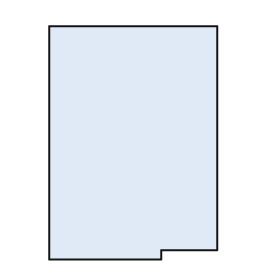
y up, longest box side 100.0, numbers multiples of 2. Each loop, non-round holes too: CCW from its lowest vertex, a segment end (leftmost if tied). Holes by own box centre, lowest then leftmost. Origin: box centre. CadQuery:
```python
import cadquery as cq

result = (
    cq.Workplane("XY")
    .moveTo(-36.0, -50.0)
    .lineTo(12.0, -50.0)
    .lineTo(12.0, -46.0)
    .lineTo(36.0, -46.0)
    .lineTo(36.0, 50.0)
    .lineTo(-36.0, 50.0)
    .close()
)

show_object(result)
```